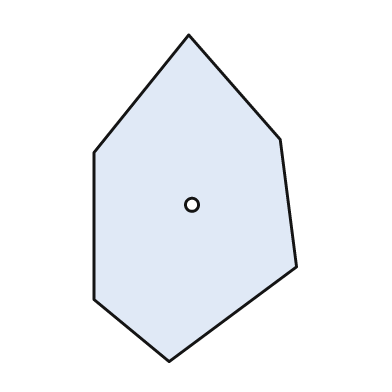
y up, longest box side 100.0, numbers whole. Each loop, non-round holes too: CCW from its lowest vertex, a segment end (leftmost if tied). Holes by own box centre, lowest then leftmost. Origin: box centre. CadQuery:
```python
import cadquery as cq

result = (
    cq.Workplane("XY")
    .moveTo(-8.0, -50.0)
    .lineTo(31.0, -21.0)
    .lineTo(26.0, 18.0)
    .lineTo(-2.0, 50.0)
    .lineTo(-31.0, 14.0)
    .lineTo(-31.0, -31.0)
    .close()
    .moveTo(-1.0, -2.0)
    .circle(2.0)
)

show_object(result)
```